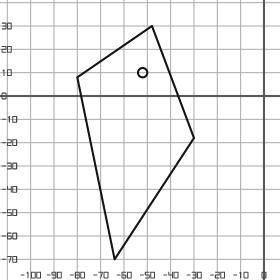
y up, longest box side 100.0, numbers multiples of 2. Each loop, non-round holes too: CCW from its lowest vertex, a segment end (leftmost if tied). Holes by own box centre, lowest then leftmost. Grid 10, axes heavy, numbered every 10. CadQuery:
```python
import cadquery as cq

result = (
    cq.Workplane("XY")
    .moveTo(-64.0, -70.0)
    .lineTo(-30.0, -18.0)
    .lineTo(-48.0, 30.0)
    .lineTo(-80.0, 8.0)
    .close()
    .moveTo(-52.0, 10.0)
    .circle(2.0)
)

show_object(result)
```